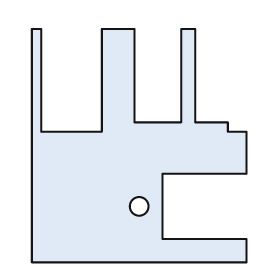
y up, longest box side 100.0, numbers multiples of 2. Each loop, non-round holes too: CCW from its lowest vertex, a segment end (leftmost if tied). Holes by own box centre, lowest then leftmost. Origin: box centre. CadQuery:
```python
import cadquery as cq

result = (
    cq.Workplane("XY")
    .moveTo(-46.0, -50.0)
    .lineTo(46.0, -50.0)
    .lineTo(46.0, -40.0)
    .lineTo(10.0, -40.0)
    .lineTo(10.0, -12.0)
    .lineTo(46.0, -12.0)
    .lineTo(46.0, 6.0)
    .lineTo(38.0, 6.0)
    .lineTo(38.0, 10.0)
    .lineTo(24.0, 10.0)
    .lineTo(24.0, 50.0)
    .lineTo(18.0, 50.0)
    .lineTo(18.0, 10.0)
    .lineTo(-2.0, 10.0)
    .lineTo(-2.0, 50.0)
    .lineTo(-16.0, 50.0)
    .lineTo(-16.0, 6.0)
    .lineTo(-42.0, 6.0)
    .lineTo(-42.0, 50.0)
    .lineTo(-46.0, 50.0)
    .close()
    .moveTo(0.0, -26.0)
    .circle(4.0)
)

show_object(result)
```